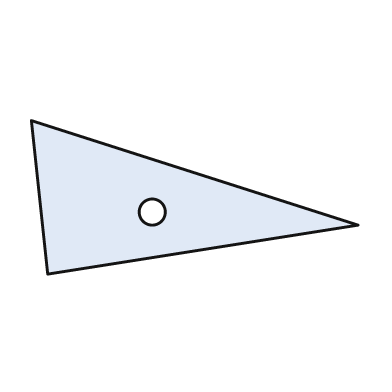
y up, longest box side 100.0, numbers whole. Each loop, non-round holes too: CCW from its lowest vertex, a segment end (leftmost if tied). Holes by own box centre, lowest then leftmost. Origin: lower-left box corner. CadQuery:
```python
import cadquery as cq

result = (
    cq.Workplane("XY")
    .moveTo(5.0, 0.0)
    .lineTo(100.0, 15.0)
    .lineTo(0.0, 47.0)
    .close()
    .moveTo(37.0, 19.0)
    .circle(4.0)
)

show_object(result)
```